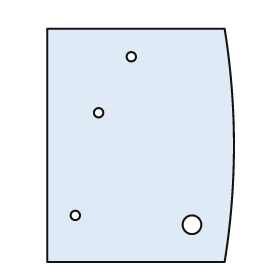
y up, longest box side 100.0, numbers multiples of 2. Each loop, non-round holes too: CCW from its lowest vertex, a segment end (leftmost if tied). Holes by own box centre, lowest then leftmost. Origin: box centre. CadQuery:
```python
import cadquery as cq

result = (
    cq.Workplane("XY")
    .moveTo(-40.0, -50.0)
    .lineTo(36.0, -50.0)
    .threePointArc((40.0, 0.0), (36.0, 50.0))
    .lineTo(-40.0, 50.0)
    .close()
    .moveTo(22.0, -34.0)
    .circle(4.0)
    .moveTo(-28.0, -30.0)
    .circle(2.0)
    .moveTo(-18.0, 14.0)
    .circle(2.0)
    .moveTo(-4.0, 38.0)
    .circle(2.0)
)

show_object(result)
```